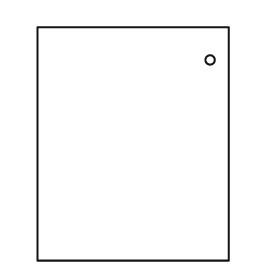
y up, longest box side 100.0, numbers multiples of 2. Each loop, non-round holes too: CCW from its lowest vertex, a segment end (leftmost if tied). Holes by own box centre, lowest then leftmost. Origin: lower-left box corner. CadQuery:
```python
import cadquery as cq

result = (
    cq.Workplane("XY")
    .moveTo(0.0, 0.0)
    .lineTo(82.0, 0.0)
    .lineTo(82.0, 100.0)
    .lineTo(0.0, 100.0)
    .close()
    .moveTo(74.0, 86.0)
    .circle(2.0)
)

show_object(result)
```